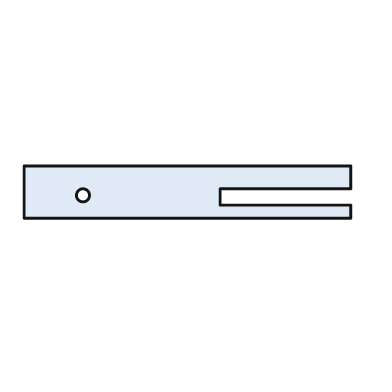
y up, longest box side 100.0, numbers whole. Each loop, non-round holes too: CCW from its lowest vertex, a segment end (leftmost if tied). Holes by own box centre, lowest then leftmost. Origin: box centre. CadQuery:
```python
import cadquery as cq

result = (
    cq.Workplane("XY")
    .moveTo(-50.0, -8.0)
    .lineTo(50.0, -8.0)
    .lineTo(50.0, -4.0)
    .lineTo(10.0, -4.0)
    .lineTo(10.0, 1.0)
    .lineTo(50.0, 1.0)
    .lineTo(50.0, 8.0)
    .lineTo(-50.0, 8.0)
    .close()
    .moveTo(-32.0, -1.0)
    .circle(2.0)
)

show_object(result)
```